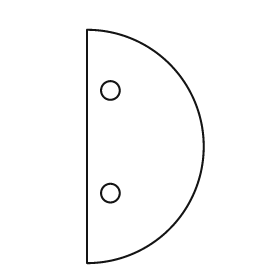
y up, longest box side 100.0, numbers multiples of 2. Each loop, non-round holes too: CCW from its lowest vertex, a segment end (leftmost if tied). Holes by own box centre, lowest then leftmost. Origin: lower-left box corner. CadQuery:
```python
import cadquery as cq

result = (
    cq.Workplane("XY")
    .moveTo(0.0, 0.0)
    .threePointArc((50.0, 50.0), (0.0, 100.0))
    .close()
    .moveTo(10.0, 30.0)
    .circle(4.0)
    .moveTo(10.0, 74.0)
    .circle(4.0)
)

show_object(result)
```